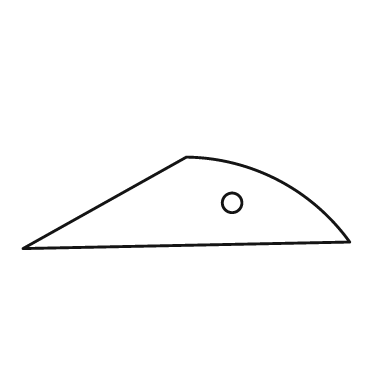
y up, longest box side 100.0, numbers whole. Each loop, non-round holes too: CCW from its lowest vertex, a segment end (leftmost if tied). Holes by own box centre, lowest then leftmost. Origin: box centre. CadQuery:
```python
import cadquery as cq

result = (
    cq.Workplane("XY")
    .moveTo(-50.0, -14.0)
    .lineTo(50.0, -12.0)
    .threePointArc((28.0, 7.0), (0.0, 14.0))
    .close()
    .moveTo(14.0, 0.0)
    .circle(3.0)
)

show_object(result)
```